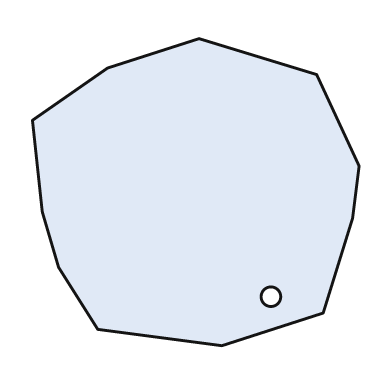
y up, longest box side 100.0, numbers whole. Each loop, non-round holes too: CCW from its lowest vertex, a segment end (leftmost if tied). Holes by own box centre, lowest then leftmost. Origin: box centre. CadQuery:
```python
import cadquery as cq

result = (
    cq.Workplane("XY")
    .moveTo(8.0, -47.0)
    .lineTo(39.0, -37.0)
    .lineTo(48.0, -8.0)
    .lineTo(50.0, 8.0)
    .lineTo(37.0, 36.0)
    .lineTo(1.0, 47.0)
    .lineTo(-27.0, 38.0)
    .lineTo(-50.0, 22.0)
    .lineTo(-47.0, -6.0)
    .lineTo(-42.0, -23.0)
    .lineTo(-30.0, -42.0)
    .close()
    .moveTo(23.0, -32.0)
    .circle(3.0)
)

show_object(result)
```